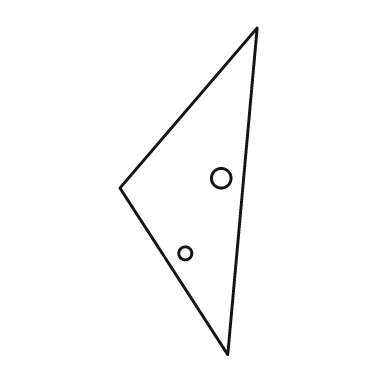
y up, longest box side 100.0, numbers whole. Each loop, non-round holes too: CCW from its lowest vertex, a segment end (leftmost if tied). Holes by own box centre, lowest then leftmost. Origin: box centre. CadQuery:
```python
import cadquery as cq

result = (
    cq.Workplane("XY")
    .moveTo(12.0, -50.0)
    .lineTo(21.0, 50.0)
    .lineTo(-21.0, 1.0)
    .close()
    .moveTo(-1.0, -19.0)
    .circle(2.0)
    .moveTo(10.0, 4.0)
    .circle(3.0)
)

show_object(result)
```